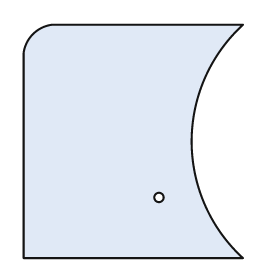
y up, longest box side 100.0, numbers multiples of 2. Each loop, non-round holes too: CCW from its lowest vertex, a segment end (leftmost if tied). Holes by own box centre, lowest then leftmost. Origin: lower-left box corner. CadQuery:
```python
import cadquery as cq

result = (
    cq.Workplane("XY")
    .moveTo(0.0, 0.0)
    .lineTo(94.0, 0.0)
    .threePointArc((72.0, 50.0), (94.0, 100.0))
    .lineTo(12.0, 100.0)
    .threePointArc((4.0, 96.0), (0.0, 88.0))
    .close()
    .moveTo(58.0, 26.0)
    .circle(2.0)
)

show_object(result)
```